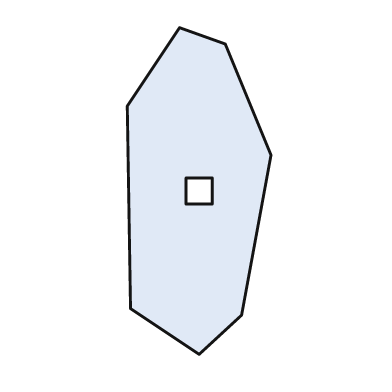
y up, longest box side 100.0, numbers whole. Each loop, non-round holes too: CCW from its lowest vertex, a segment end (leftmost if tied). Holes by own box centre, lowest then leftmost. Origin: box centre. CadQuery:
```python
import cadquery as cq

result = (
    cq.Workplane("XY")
    .moveTo(0.0, -50.0)
    .lineTo(13.0, -38.0)
    .lineTo(22.0, 11.0)
    .lineTo(8.0, 45.0)
    .lineTo(-6.0, 50.0)
    .lineTo(-22.0, 26.0)
    .lineTo(-21.0, -36.0)
    .close()
    .moveTo(-4.0, -4.0)
    .lineTo(4.0, -4.0)
    .lineTo(4.0, 4.0)
    .lineTo(-4.0, 4.0)
    .close()
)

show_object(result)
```